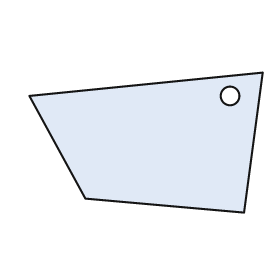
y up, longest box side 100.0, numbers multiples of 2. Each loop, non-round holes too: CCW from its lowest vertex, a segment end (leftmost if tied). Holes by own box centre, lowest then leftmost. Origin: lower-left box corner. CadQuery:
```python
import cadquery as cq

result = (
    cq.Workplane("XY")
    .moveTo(92.0, 0.0)
    .lineTo(100.0, 60.0)
    .lineTo(0.0, 50.0)
    .lineTo(24.0, 6.0)
    .close()
    .moveTo(86.0, 50.0)
    .circle(4.0)
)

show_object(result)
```